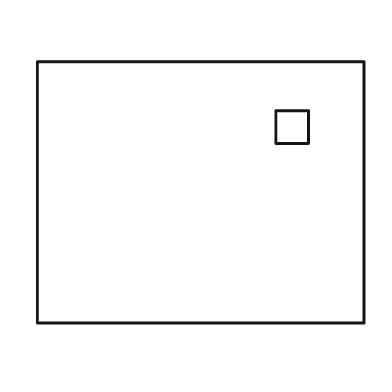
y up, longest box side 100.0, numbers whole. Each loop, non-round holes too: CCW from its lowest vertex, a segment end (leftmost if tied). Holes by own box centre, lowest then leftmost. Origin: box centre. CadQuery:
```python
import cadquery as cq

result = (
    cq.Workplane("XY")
    .moveTo(-50.0, -40.0)
    .lineTo(50.0, -40.0)
    .lineTo(50.0, 40.0)
    .lineTo(-50.0, 40.0)
    .close()
    .moveTo(23.0, 15.0)
    .lineTo(33.0, 15.0)
    .lineTo(33.0, 25.0)
    .lineTo(23.0, 25.0)
    .close()
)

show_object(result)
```